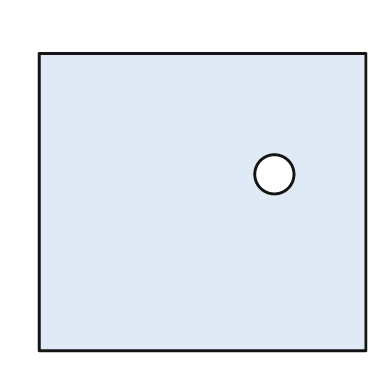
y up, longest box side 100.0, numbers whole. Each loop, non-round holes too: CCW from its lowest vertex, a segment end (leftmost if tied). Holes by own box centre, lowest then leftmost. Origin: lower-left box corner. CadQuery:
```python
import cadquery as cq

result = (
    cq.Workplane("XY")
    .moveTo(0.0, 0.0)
    .lineTo(100.0, 0.0)
    .lineTo(100.0, 91.0)
    .lineTo(0.0, 91.0)
    .close()
    .moveTo(72.0, 54.0)
    .circle(6.0)
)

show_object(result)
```